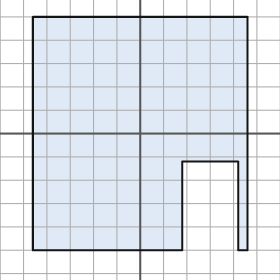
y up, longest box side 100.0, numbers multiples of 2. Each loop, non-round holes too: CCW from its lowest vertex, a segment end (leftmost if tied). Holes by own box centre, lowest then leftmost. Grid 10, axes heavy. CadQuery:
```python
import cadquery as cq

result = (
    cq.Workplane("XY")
    .moveTo(-46.0, -50.0)
    .lineTo(18.0, -50.0)
    .lineTo(18.0, -12.0)
    .lineTo(42.0, -12.0)
    .lineTo(42.0, -50.0)
    .lineTo(46.0, -50.0)
    .lineTo(46.0, 50.0)
    .lineTo(-46.0, 50.0)
    .close()
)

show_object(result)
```